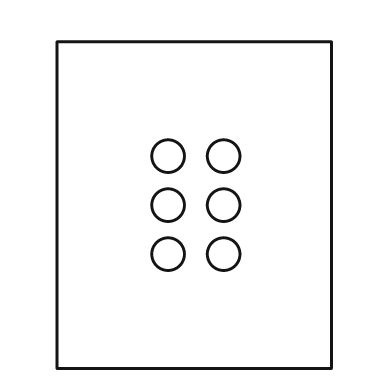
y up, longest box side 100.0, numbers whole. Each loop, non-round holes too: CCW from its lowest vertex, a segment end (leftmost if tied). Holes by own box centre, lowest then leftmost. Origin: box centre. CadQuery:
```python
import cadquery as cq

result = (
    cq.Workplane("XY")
    .moveTo(-42.0, -50.0)
    .lineTo(42.0, -50.0)
    .lineTo(42.0, 50.0)
    .lineTo(-42.0, 50.0)
    .close()
    .moveTo(-8.0, -15.0)
    .circle(5.0)
    .moveTo(9.0, -15.0)
    .circle(5.0)
    .moveTo(-8.0, 0.0)
    .circle(5.0)
    .moveTo(9.0, 0.0)
    .circle(5.0)
    .moveTo(-8.0, 15.0)
    .circle(5.0)
    .moveTo(9.0, 15.0)
    .circle(5.0)
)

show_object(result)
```